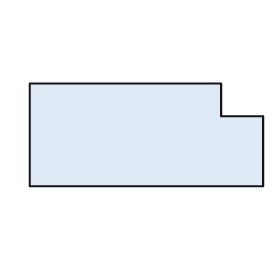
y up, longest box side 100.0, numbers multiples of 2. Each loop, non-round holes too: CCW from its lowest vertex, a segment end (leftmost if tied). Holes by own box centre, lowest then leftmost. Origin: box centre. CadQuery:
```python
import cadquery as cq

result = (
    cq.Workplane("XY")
    .moveTo(-50.0, -22.0)
    .lineTo(50.0, -22.0)
    .lineTo(50.0, 8.0)
    .lineTo(32.0, 8.0)
    .lineTo(32.0, 22.0)
    .lineTo(-50.0, 22.0)
    .close()
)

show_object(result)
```